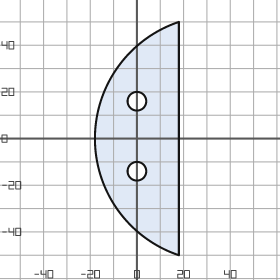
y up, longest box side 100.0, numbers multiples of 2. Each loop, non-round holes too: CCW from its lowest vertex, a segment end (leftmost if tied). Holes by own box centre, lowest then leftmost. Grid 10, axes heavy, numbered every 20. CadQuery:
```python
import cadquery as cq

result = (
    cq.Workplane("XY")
    .moveTo(18.0, -50.0)
    .lineTo(18.0, 50.0)
    .threePointArc((-18.0, 0.0), (18.0, -50.0))
    .close()
    .moveTo(0.0, -14.0)
    .circle(4.0)
    .moveTo(0.0, 16.0)
    .circle(4.0)
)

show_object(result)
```